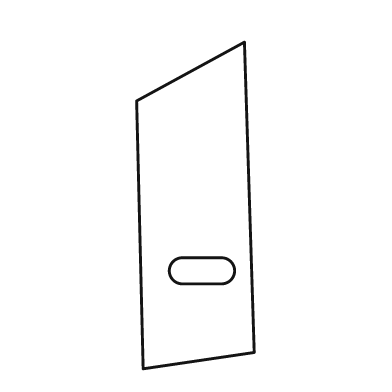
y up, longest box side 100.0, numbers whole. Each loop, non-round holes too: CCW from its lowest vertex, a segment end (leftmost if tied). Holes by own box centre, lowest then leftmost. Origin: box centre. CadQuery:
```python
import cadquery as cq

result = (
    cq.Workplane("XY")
    .moveTo(-16.0, -50.0)
    .lineTo(18.0, -45.0)
    .lineTo(15.0, 50.0)
    .lineTo(-18.0, 32.0)
    .close()
    .moveTo(-4.0, -24.0)
    .lineTo(8.0, -24.0)
    .threePointArc((12.0, -20.0), (8.0, -16.0))
    .lineTo(-4.0, -16.0)
    .threePointArc((-8.0, -20.0), (-4.0, -24.0))
    .close()
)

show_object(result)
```